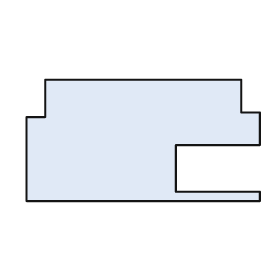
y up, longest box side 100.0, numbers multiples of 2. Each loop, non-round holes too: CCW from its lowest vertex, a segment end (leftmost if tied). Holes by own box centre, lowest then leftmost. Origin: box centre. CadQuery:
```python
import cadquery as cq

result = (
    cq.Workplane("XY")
    .moveTo(-50.0, -26.0)
    .lineTo(50.0, -26.0)
    .lineTo(50.0, -22.0)
    .lineTo(14.0, -22.0)
    .lineTo(14.0, -2.0)
    .lineTo(50.0, -2.0)
    .lineTo(50.0, 12.0)
    .lineTo(42.0, 12.0)
    .lineTo(42.0, 26.0)
    .lineTo(-42.0, 26.0)
    .lineTo(-42.0, 10.0)
    .lineTo(-50.0, 10.0)
    .close()
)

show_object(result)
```